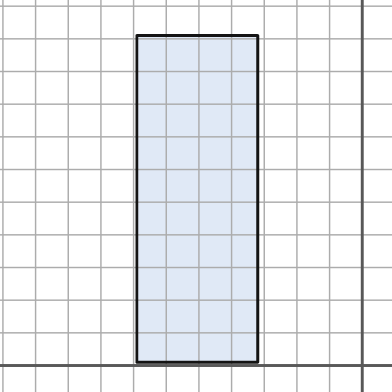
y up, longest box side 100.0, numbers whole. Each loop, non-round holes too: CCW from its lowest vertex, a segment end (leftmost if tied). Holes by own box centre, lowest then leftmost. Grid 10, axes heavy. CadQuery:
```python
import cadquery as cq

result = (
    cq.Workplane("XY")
    .moveTo(-69.0, 1.0)
    .lineTo(-32.0, 1.0)
    .lineTo(-32.0, 101.0)
    .lineTo(-69.0, 101.0)
    .close()
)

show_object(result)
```